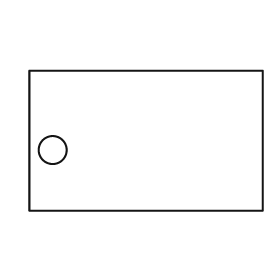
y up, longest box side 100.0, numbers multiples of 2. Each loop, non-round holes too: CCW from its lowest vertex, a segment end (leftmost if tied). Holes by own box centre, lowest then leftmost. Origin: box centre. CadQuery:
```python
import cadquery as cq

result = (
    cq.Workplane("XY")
    .moveTo(-50.0, -30.0)
    .lineTo(50.0, -30.0)
    .lineTo(50.0, 30.0)
    .lineTo(-50.0, 30.0)
    .close()
    .moveTo(-40.0, -4.0)
    .circle(6.0)
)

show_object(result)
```